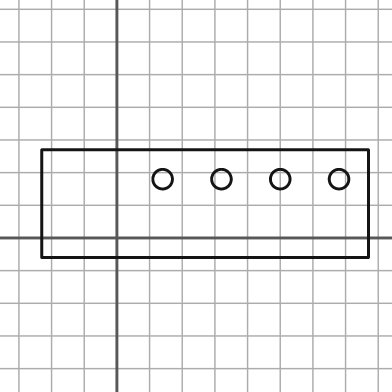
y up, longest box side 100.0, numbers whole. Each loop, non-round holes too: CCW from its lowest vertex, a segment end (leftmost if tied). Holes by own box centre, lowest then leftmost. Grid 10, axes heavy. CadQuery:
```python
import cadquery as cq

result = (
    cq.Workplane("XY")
    .moveTo(-23.0, -6.0)
    .lineTo(77.0, -6.0)
    .lineTo(77.0, 27.0)
    .lineTo(-23.0, 27.0)
    .close()
    .moveTo(14.0, 18.0)
    .circle(3.0)
    .moveTo(32.0, 18.0)
    .circle(3.0)
    .moveTo(50.0, 18.0)
    .circle(3.0)
    .moveTo(68.0, 18.0)
    .circle(3.0)
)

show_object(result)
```